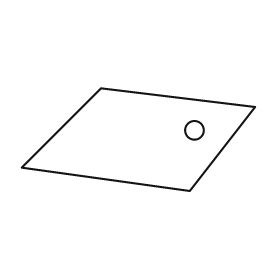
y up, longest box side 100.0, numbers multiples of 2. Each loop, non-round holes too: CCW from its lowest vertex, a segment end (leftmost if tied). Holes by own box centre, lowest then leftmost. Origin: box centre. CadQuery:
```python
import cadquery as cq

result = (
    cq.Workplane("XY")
    .moveTo(22.0, -22.0)
    .lineTo(50.0, 14.0)
    .lineTo(-16.0, 22.0)
    .lineTo(-50.0, -12.0)
    .close()
    .moveTo(24.0, 4.0)
    .circle(4.0)
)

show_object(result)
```